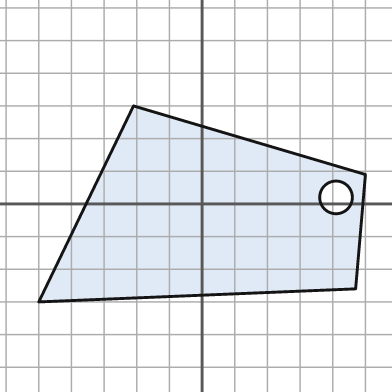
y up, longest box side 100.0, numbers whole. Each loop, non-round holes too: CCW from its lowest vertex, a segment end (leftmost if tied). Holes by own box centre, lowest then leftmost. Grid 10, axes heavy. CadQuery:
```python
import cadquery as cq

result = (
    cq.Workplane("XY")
    .moveTo(-50.0, -30.0)
    .lineTo(47.0, -26.0)
    .lineTo(50.0, 9.0)
    .lineTo(-21.0, 30.0)
    .close()
    .moveTo(41.0, 2.0)
    .circle(5.0)
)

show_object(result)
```